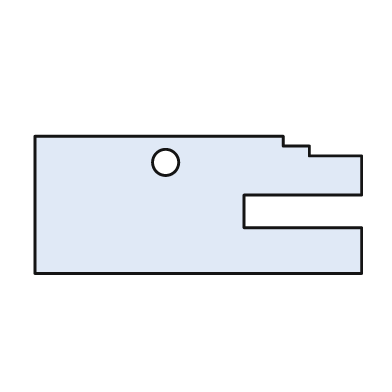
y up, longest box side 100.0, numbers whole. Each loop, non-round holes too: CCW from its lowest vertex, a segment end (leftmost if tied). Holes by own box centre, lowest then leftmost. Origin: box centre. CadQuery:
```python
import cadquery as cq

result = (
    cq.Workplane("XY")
    .moveTo(-50.0, -21.0)
    .lineTo(50.0, -21.0)
    .lineTo(50.0, -7.0)
    .lineTo(14.0, -7.0)
    .lineTo(14.0, 3.0)
    .lineTo(50.0, 3.0)
    .lineTo(50.0, 15.0)
    .lineTo(34.0, 15.0)
    .lineTo(34.0, 18.0)
    .lineTo(26.0, 18.0)
    .lineTo(26.0, 21.0)
    .lineTo(-50.0, 21.0)
    .close()
    .moveTo(-10.0, 13.0)
    .circle(4.0)
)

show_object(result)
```